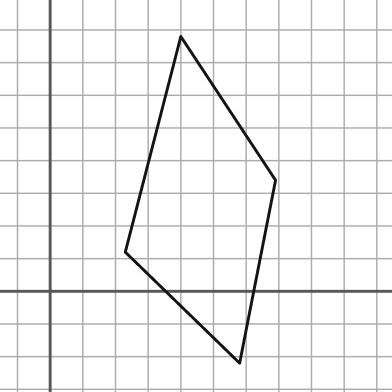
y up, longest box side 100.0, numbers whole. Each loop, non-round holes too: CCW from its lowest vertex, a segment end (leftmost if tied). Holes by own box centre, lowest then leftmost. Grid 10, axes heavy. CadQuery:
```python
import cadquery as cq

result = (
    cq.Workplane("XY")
    .moveTo(58.0, -22.0)
    .lineTo(69.0, 34.0)
    .lineTo(40.0, 78.0)
    .lineTo(23.0, 12.0)
    .close()
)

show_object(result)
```